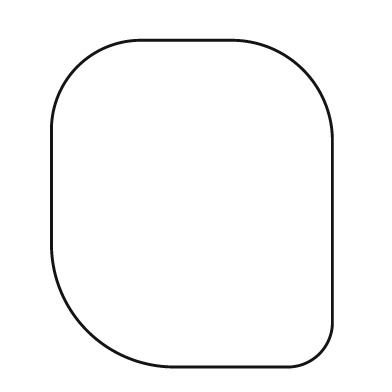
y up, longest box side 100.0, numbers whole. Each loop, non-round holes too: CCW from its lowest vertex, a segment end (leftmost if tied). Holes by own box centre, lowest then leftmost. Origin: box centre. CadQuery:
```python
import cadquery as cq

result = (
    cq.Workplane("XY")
    .moveTo(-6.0, -50.0)
    .lineTo(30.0, -50.0)
    .threePointArc((39.0, -46.0), (43.0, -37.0))
    .lineTo(43.0, 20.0)
    .threePointArc((34.0, 41.0), (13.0, 50.0))
    .lineTo(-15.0, 50.0)
    .threePointArc((-35.0, 42.0), (-43.0, 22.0))
    .lineTo(-43.0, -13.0)
    .threePointArc((-32.0, -39.0), (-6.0, -50.0))
    .close()
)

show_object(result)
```